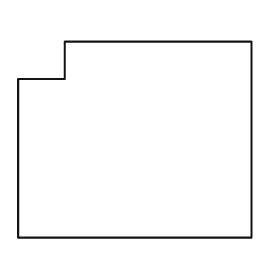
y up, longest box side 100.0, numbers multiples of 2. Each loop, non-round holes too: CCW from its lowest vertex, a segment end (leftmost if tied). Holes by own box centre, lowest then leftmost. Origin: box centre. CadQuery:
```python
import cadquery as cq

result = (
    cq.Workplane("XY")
    .moveTo(-50.0, -42.0)
    .lineTo(50.0, -42.0)
    .lineTo(50.0, 42.0)
    .lineTo(-30.0, 42.0)
    .lineTo(-30.0, 26.0)
    .lineTo(-50.0, 26.0)
    .close()
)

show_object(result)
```